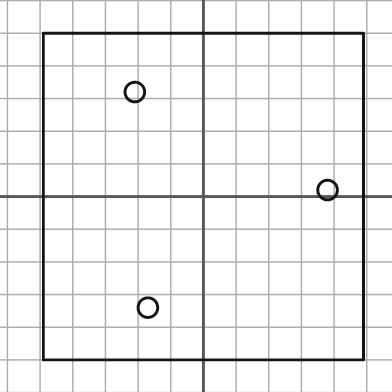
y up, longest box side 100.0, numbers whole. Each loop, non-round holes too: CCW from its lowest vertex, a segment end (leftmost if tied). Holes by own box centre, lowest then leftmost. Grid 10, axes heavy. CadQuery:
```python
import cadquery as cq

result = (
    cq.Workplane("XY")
    .moveTo(-49.0, -50.0)
    .lineTo(49.0, -50.0)
    .lineTo(49.0, 50.0)
    .lineTo(-49.0, 50.0)
    .close()
    .moveTo(-17.0, -34.0)
    .circle(3.0)
    .moveTo(38.0, 2.0)
    .circle(3.0)
    .moveTo(-21.0, 32.0)
    .circle(3.0)
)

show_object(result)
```